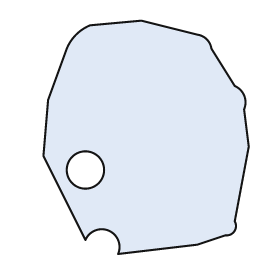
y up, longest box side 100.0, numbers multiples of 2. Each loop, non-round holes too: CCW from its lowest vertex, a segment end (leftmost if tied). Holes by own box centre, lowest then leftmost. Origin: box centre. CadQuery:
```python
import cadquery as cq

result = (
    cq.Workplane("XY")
    .moveTo(-12.0, -50.0)
    .lineTo(22.0, -46.0)
    .lineTo(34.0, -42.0)
    .threePointArc((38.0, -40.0), (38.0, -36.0))
    .lineTo(44.0, -4.0)
    .lineTo(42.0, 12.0)
    .threePointArc((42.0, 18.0), (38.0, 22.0))
    .lineTo(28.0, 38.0)
    .threePointArc((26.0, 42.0), (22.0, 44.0))
    .lineTo(-2.0, 50.0)
    .lineTo(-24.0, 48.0)
    .threePointArc((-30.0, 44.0), (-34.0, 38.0))
    .lineTo(-42.0, 16.0)
    .lineTo(-44.0, -8.0)
    .lineTo(-26.0, -44.0)
    .threePointArc((-16.0, -40.0), (-12.0, -50.0))
    .close()
    .moveTo(-26.0, -14.0)
    .circle(8.0)
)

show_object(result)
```